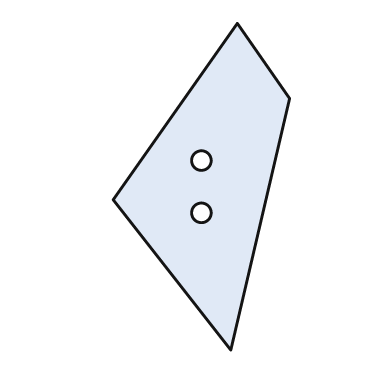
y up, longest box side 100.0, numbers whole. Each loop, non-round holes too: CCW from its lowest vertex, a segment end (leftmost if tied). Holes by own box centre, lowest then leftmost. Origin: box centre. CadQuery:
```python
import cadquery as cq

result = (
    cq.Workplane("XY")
    .moveTo(9.0, -50.0)
    .lineTo(27.0, 27.0)
    .lineTo(11.0, 50.0)
    .lineTo(-27.0, -4.0)
    .close()
    .moveTo(0.0, -8.0)
    .circle(3.0)
    .moveTo(0.0, 8.0)
    .circle(3.0)
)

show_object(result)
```